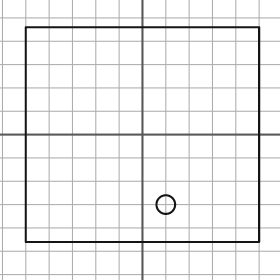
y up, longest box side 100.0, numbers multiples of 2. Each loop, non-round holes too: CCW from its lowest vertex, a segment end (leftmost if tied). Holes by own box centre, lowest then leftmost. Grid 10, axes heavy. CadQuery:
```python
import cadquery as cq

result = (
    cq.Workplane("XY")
    .moveTo(-50.0, -46.0)
    .lineTo(50.0, -46.0)
    .lineTo(50.0, 46.0)
    .lineTo(-50.0, 46.0)
    .close()
    .moveTo(10.0, -30.0)
    .circle(4.0)
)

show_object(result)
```